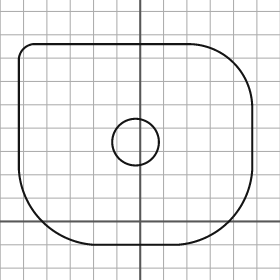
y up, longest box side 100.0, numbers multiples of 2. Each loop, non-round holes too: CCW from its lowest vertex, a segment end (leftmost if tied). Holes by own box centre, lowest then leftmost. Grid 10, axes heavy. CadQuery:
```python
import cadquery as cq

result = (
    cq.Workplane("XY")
    .moveTo(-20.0, -10.0)
    .lineTo(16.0, -10.0)
    .threePointArc((38.0, 0.0), (48.0, 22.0))
    .lineTo(48.0, 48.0)
    .threePointArc((40.0, 68.0), (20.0, 76.0))
    .lineTo(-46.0, 76.0)
    .threePointArc((-50.0, 74.0), (-52.0, 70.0))
    .lineTo(-52.0, 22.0)
    .threePointArc((-42.0, 0.0), (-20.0, -10.0))
    .close()
    .moveTo(-2.0, 34.0)
    .circle(10.0)
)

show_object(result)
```